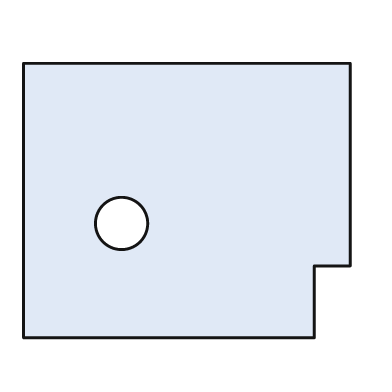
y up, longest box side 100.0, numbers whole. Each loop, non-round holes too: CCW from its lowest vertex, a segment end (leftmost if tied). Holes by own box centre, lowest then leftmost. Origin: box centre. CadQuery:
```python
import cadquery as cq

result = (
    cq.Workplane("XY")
    .moveTo(-50.0, -42.0)
    .lineTo(39.0, -42.0)
    .lineTo(39.0, -20.0)
    .lineTo(50.0, -20.0)
    .lineTo(50.0, 42.0)
    .lineTo(-50.0, 42.0)
    .close()
    .moveTo(-20.0, -7.0)
    .circle(8.0)
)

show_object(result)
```